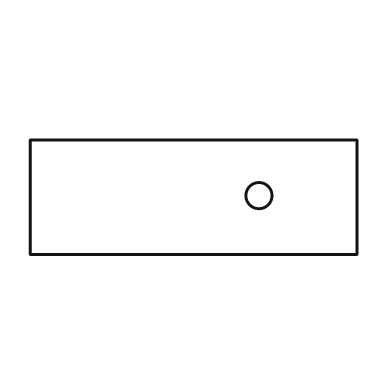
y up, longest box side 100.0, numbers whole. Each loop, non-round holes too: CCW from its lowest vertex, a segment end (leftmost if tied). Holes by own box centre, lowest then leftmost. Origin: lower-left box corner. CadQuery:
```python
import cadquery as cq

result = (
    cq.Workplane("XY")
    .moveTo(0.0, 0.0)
    .lineTo(100.0, 0.0)
    .lineTo(100.0, 35.0)
    .lineTo(0.0, 35.0)
    .close()
    .moveTo(70.0, 18.0)
    .circle(4.0)
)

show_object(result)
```